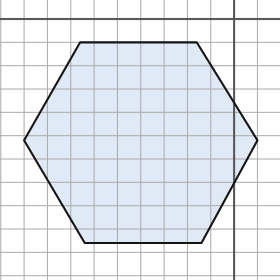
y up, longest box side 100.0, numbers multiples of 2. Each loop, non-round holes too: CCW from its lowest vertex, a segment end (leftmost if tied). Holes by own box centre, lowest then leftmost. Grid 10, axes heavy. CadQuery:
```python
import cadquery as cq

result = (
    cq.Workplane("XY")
    .moveTo(-64.0, -96.0)
    .lineTo(-14.0, -96.0)
    .lineTo(10.0, -52.0)
    .lineTo(-16.0, -10.0)
    .lineTo(-66.0, -10.0)
    .lineTo(-90.0, -52.0)
    .close()
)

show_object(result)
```